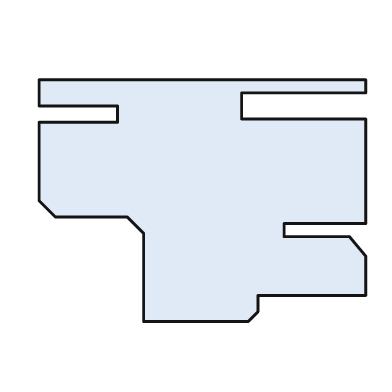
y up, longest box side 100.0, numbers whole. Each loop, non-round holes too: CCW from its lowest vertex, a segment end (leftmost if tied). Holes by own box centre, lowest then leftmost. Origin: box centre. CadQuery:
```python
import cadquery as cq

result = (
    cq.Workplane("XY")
    .moveTo(-18.0, -37.0)
    .lineTo(14.0, -37.0)
    .lineTo(17.0, -34.0)
    .lineTo(17.0, -29.0)
    .lineTo(50.0, -29.0)
    .lineTo(50.0, -17.0)
    .lineTo(45.0, -11.0)
    .lineTo(25.0, -11.0)
    .lineTo(25.0, -7.0)
    .lineTo(50.0, -7.0)
    .lineTo(50.0, 25.0)
    .lineTo(12.0, 25.0)
    .lineTo(12.0, 33.0)
    .lineTo(50.0, 33.0)
    .lineTo(50.0, 37.0)
    .lineTo(-50.0, 37.0)
    .lineTo(-50.0, 29.0)
    .lineTo(-26.0, 29.0)
    .lineTo(-26.0, 24.0)
    .lineTo(-50.0, 24.0)
    .lineTo(-50.0, 0.0)
    .lineTo(-45.0, -5.0)
    .lineTo(-23.0, -5.0)
    .lineTo(-18.0, -10.0)
    .close()
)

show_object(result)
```